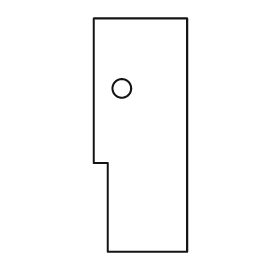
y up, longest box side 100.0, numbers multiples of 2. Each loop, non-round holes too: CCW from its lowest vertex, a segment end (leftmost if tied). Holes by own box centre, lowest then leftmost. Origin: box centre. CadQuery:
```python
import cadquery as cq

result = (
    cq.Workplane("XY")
    .moveTo(-14.0, -50.0)
    .lineTo(20.0, -50.0)
    .lineTo(20.0, 50.0)
    .lineTo(-20.0, 50.0)
    .lineTo(-20.0, -12.0)
    .lineTo(-14.0, -12.0)
    .close()
    .moveTo(-8.0, 20.0)
    .circle(4.0)
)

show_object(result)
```